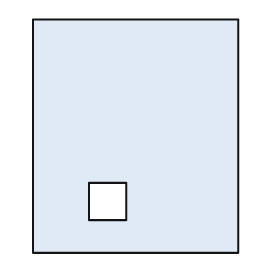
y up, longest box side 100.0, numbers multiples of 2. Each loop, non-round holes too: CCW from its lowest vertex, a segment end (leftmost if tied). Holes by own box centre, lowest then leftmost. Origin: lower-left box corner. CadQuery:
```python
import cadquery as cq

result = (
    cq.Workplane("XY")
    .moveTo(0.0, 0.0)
    .lineTo(88.0, 0.0)
    .lineTo(88.0, 100.0)
    .lineTo(0.0, 100.0)
    .close()
    .moveTo(24.0, 14.0)
    .lineTo(40.0, 14.0)
    .lineTo(40.0, 30.0)
    .lineTo(24.0, 30.0)
    .close()
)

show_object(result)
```